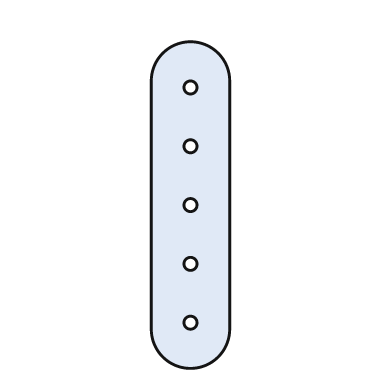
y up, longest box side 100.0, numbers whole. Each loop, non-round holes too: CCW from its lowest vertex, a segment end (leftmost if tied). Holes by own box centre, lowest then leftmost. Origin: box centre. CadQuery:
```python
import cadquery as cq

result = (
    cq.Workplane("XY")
    .moveTo(-12.0, -38.0)
    .threePointArc((0.0, -50.0), (12.0, -38.0))
    .lineTo(12.0, 38.0)
    .threePointArc((0.0, 50.0), (-12.0, 38.0))
    .close()
    .moveTo(0.0, -36.0)
    .circle(2.0)
    .moveTo(0.0, -18.0)
    .circle(2.0)
    .moveTo(0.0, 0.0)
    .circle(2.0)
    .moveTo(0.0, 18.0)
    .circle(2.0)
    .moveTo(0.0, 36.0)
    .circle(2.0)
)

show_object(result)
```